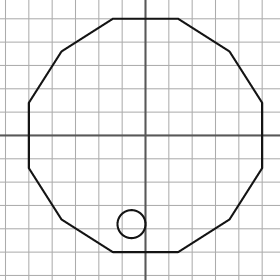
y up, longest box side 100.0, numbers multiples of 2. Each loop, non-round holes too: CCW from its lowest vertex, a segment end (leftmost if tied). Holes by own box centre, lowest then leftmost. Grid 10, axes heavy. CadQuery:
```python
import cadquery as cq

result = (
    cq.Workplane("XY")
    .moveTo(-14.0, -50.0)
    .lineTo(14.0, -50.0)
    .lineTo(36.0, -36.0)
    .lineTo(50.0, -14.0)
    .lineTo(50.0, 14.0)
    .lineTo(36.0, 36.0)
    .lineTo(14.0, 50.0)
    .lineTo(-14.0, 50.0)
    .lineTo(-36.0, 36.0)
    .lineTo(-50.0, 14.0)
    .lineTo(-50.0, -14.0)
    .lineTo(-36.0, -36.0)
    .close()
    .moveTo(-6.0, -38.0)
    .circle(6.0)
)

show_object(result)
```